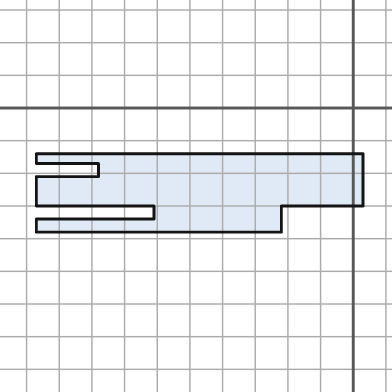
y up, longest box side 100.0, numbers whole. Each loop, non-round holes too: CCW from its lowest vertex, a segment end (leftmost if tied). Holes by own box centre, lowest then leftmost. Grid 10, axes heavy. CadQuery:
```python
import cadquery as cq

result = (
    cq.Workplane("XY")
    .moveTo(-97.0, -38.0)
    .lineTo(-22.0, -38.0)
    .lineTo(-22.0, -30.0)
    .lineTo(3.0, -30.0)
    .lineTo(3.0, -14.0)
    .lineTo(-97.0, -14.0)
    .lineTo(-97.0, -17.0)
    .lineTo(-78.0, -17.0)
    .lineTo(-78.0, -21.0)
    .lineTo(-97.0, -21.0)
    .lineTo(-97.0, -30.0)
    .lineTo(-61.0, -30.0)
    .lineTo(-61.0, -34.0)
    .lineTo(-97.0, -34.0)
    .close()
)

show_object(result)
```